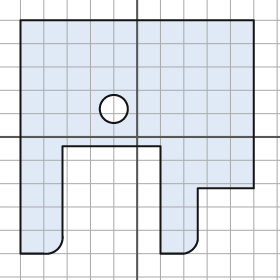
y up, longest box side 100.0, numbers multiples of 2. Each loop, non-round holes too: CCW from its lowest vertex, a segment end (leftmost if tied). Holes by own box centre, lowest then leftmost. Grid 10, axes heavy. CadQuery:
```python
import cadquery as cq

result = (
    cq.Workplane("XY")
    .moveTo(-50.0, -50.0)
    .lineTo(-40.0, -50.0)
    .threePointArc((-34.0, -48.0), (-32.0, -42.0))
    .lineTo(-32.0, -4.0)
    .lineTo(10.0, -4.0)
    .lineTo(10.0, -50.0)
    .lineTo(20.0, -50.0)
    .threePointArc((24.0, -48.0), (26.0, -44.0))
    .lineTo(26.0, -22.0)
    .lineTo(50.0, -22.0)
    .lineTo(50.0, 50.0)
    .lineTo(-50.0, 50.0)
    .close()
    .moveTo(-10.0, 12.0)
    .circle(6.0)
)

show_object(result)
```